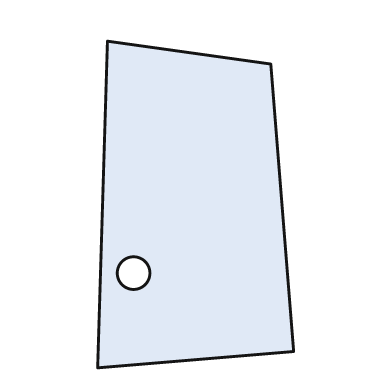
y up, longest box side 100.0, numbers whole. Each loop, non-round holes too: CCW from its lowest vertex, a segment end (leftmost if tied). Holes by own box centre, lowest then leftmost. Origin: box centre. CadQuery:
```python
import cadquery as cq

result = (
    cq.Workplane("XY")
    .moveTo(-30.0, -50.0)
    .lineTo(30.0, -45.0)
    .lineTo(23.0, 43.0)
    .lineTo(-27.0, 50.0)
    .close()
    .moveTo(-19.0, -21.0)
    .circle(5.0)
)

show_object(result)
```